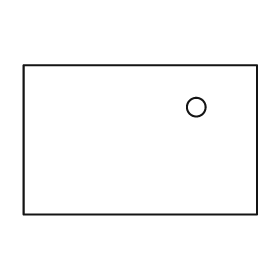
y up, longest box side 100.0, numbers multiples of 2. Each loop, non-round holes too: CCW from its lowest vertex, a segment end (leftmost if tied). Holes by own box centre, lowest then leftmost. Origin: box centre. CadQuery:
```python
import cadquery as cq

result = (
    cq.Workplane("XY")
    .moveTo(-50.0, -32.0)
    .lineTo(50.0, -32.0)
    .lineTo(50.0, 32.0)
    .lineTo(-50.0, 32.0)
    .close()
    .moveTo(24.0, 14.0)
    .circle(4.0)
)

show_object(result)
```